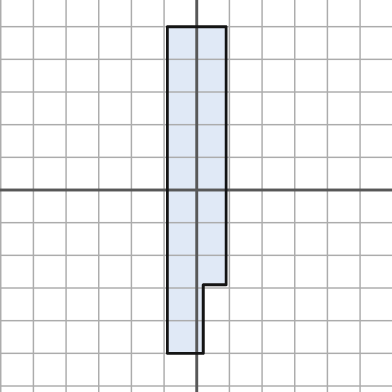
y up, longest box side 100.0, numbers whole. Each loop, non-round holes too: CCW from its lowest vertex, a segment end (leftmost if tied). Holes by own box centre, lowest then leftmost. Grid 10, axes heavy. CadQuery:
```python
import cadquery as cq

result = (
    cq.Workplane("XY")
    .moveTo(-9.0, -50.0)
    .lineTo(2.0, -50.0)
    .lineTo(2.0, -29.0)
    .lineTo(9.0, -29.0)
    .lineTo(9.0, 50.0)
    .lineTo(-9.0, 50.0)
    .close()
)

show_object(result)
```